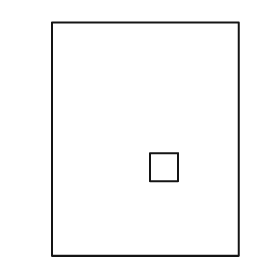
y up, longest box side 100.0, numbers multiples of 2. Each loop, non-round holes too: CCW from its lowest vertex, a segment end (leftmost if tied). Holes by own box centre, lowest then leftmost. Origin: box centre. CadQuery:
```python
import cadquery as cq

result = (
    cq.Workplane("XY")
    .moveTo(-40.0, -50.0)
    .lineTo(40.0, -50.0)
    .lineTo(40.0, 50.0)
    .lineTo(-40.0, 50.0)
    .close()
    .moveTo(2.0, -18.0)
    .lineTo(14.0, -18.0)
    .lineTo(14.0, -6.0)
    .lineTo(2.0, -6.0)
    .close()
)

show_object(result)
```